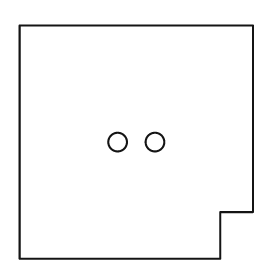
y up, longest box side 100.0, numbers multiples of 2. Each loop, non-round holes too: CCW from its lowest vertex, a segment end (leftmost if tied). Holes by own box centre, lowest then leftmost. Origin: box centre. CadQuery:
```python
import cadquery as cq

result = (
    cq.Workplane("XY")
    .moveTo(-50.0, -50.0)
    .lineTo(36.0, -50.0)
    .lineTo(36.0, -30.0)
    .lineTo(50.0, -30.0)
    .lineTo(50.0, 50.0)
    .lineTo(-50.0, 50.0)
    .close()
    .moveTo(-8.0, 0.0)
    .circle(4.0)
    .moveTo(8.0, 0.0)
    .circle(4.0)
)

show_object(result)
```